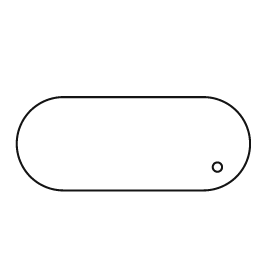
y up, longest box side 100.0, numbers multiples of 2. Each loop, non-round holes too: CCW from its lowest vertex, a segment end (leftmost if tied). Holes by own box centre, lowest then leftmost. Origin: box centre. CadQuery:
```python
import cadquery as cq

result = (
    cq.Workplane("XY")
    .moveTo(-30.0, -20.0)
    .lineTo(30.0, -20.0)
    .threePointArc((50.0, 0.0), (30.0, 20.0))
    .lineTo(-30.0, 20.0)
    .threePointArc((-50.0, 0.0), (-30.0, -20.0))
    .close()
    .moveTo(36.0, -10.0)
    .circle(2.0)
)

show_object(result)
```